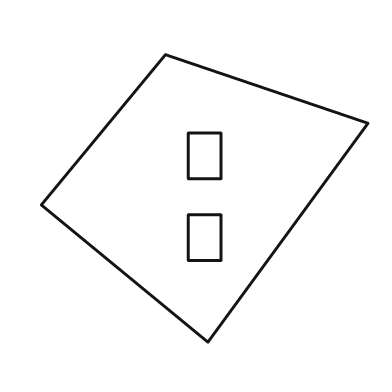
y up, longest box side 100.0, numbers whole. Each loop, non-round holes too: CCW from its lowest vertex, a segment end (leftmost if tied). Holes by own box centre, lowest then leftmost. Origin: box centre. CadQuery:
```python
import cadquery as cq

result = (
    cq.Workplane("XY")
    .moveTo(1.0, -44.0)
    .lineTo(50.0, 23.0)
    .lineTo(-12.0, 44.0)
    .lineTo(-50.0, -2.0)
    .close()
    .moveTo(-5.0, -19.0)
    .lineTo(5.0, -19.0)
    .lineTo(5.0, -5.0)
    .lineTo(-5.0, -5.0)
    .close()
    .moveTo(-5.0, 6.0)
    .lineTo(5.0, 6.0)
    .lineTo(5.0, 20.0)
    .lineTo(-5.0, 20.0)
    .close()
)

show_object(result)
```